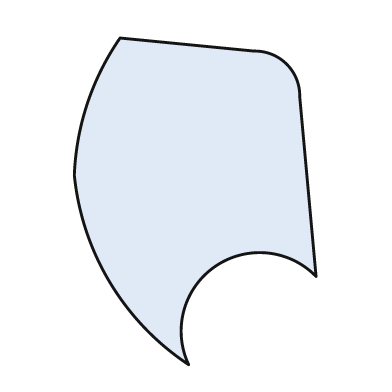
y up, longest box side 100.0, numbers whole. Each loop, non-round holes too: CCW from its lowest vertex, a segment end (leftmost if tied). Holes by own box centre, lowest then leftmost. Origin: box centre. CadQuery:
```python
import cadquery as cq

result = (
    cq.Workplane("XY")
    .moveTo(-2.0, -50.0)
    .threePointArc((6.0, -20.0), (37.0, -23.0))
    .lineTo(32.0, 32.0)
    .threePointArc((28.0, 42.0), (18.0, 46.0))
    .lineTo(-23.0, 50.0)
    .threePointArc((-33.0, 30.0), (-37.0, 8.0))
    .threePointArc((-26.0, -25.0), (-2.0, -50.0))
    .close()
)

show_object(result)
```